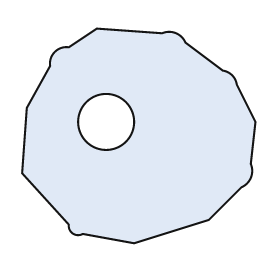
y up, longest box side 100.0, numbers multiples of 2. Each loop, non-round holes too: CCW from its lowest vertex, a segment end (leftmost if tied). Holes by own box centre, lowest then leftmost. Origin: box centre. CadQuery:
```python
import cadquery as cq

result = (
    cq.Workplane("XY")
    .moveTo(-2.0, -46.0)
    .lineTo(30.0, -36.0)
    .lineTo(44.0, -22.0)
    .threePointArc((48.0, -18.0), (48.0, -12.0))
    .lineTo(50.0, 6.0)
    .lineTo(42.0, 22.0)
    .threePointArc((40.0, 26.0), (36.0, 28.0))
    .lineTo(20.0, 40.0)
    .threePointArc((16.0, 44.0), (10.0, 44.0))
    .lineTo(-18.0, 46.0)
    .lineTo(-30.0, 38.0)
    .threePointArc((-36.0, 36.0), (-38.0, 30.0))
    .lineTo(-48.0, 12.0)
    .lineTo(-50.0, -16.0)
    .lineTo(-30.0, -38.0)
    .threePointArc((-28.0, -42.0), (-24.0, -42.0))
    .close()
    .moveTo(-14.0, 6.0)
    .circle(12.0)
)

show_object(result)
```